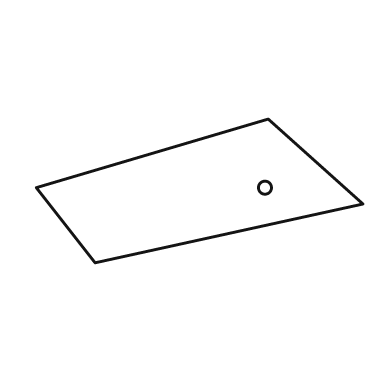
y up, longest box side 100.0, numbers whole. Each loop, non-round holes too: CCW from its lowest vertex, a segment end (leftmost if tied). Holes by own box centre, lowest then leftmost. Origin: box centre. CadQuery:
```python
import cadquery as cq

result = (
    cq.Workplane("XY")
    .moveTo(-32.0, -22.0)
    .lineTo(50.0, -4.0)
    .lineTo(21.0, 22.0)
    .lineTo(-50.0, 1.0)
    .close()
    .moveTo(20.0, 1.0)
    .circle(2.0)
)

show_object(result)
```